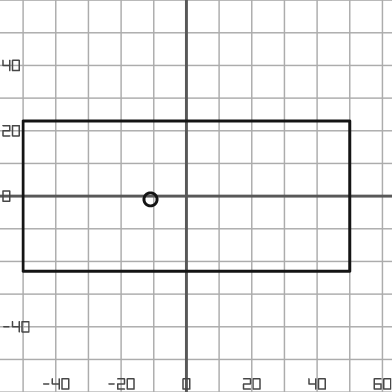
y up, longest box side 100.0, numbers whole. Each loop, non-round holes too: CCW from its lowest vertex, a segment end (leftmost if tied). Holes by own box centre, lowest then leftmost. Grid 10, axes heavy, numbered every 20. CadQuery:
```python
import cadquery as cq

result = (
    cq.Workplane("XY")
    .moveTo(-50.0, -23.0)
    .lineTo(50.0, -23.0)
    .lineTo(50.0, 23.0)
    .lineTo(-50.0, 23.0)
    .close()
    .moveTo(-11.0, -1.0)
    .circle(2.0)
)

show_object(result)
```